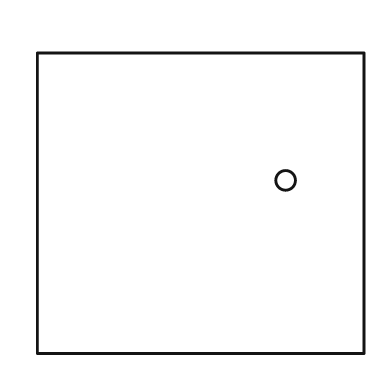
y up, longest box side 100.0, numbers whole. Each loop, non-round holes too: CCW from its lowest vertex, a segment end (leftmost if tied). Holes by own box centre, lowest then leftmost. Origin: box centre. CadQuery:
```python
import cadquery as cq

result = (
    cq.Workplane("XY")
    .moveTo(-50.0, -46.0)
    .lineTo(50.0, -46.0)
    .lineTo(50.0, 46.0)
    .lineTo(-50.0, 46.0)
    .close()
    .moveTo(26.0, 7.0)
    .circle(3.0)
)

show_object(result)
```